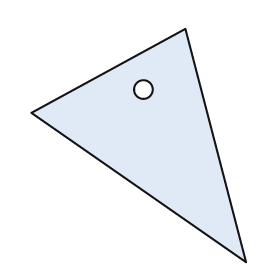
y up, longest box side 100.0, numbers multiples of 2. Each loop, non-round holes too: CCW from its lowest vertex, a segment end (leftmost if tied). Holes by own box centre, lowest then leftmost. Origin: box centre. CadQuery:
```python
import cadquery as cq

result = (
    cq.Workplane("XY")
    .moveTo(46.0, -50.0)
    .lineTo(20.0, 50.0)
    .lineTo(-46.0, 14.0)
    .close()
    .moveTo(2.0, 24.0)
    .circle(4.0)
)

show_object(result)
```